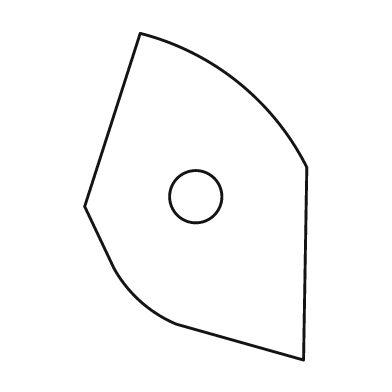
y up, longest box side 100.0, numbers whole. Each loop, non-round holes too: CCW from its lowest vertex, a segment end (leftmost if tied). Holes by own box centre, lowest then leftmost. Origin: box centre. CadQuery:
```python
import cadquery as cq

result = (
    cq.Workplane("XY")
    .moveTo(33.0, -50.0)
    .lineTo(34.0, 9.0)
    .threePointArc((13.0, 35.0), (-17.0, 50.0))
    .lineTo(-34.0, -3.0)
    .lineTo(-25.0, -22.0)
    .threePointArc((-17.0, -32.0), (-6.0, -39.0))
    .close()
    .moveTo(0.0, 0.0)
    .circle(8.0)
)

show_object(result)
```